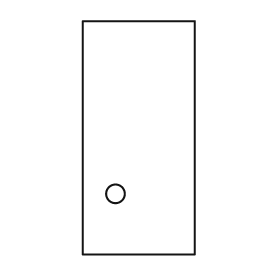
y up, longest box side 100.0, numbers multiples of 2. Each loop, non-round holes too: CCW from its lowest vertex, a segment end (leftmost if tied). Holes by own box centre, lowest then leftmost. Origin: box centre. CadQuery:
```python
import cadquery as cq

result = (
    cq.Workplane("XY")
    .moveTo(-24.0, -50.0)
    .lineTo(24.0, -50.0)
    .lineTo(24.0, 50.0)
    .lineTo(-24.0, 50.0)
    .close()
    .moveTo(-10.0, -24.0)
    .circle(4.0)
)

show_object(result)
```